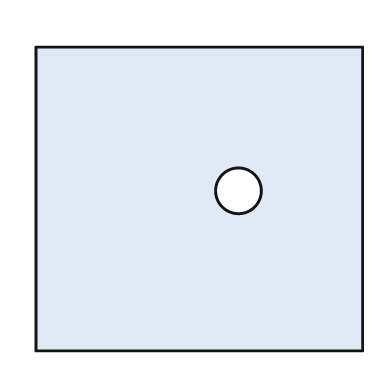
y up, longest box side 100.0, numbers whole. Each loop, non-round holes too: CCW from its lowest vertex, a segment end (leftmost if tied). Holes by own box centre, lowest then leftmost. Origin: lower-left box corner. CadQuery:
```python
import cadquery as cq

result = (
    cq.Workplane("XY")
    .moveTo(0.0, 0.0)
    .lineTo(100.0, 0.0)
    .lineTo(100.0, 93.0)
    .lineTo(0.0, 93.0)
    .close()
    .moveTo(62.0, 49.0)
    .circle(7.0)
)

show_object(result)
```